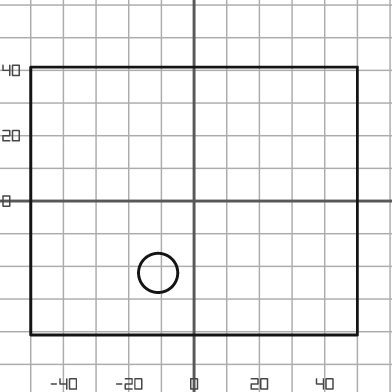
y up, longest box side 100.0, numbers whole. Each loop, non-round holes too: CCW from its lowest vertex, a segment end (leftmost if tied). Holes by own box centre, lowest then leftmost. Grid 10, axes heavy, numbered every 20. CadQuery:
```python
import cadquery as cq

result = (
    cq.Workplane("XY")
    .moveTo(-50.0, -41.0)
    .lineTo(50.0, -41.0)
    .lineTo(50.0, 41.0)
    .lineTo(-50.0, 41.0)
    .close()
    .moveTo(-11.0, -22.0)
    .circle(6.0)
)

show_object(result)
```